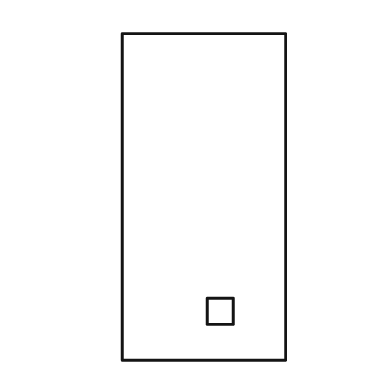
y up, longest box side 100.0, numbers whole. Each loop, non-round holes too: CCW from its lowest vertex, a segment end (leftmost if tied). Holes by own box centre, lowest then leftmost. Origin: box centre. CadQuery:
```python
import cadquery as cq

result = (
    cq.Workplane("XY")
    .moveTo(-25.0, -50.0)
    .lineTo(25.0, -50.0)
    .lineTo(25.0, 50.0)
    .lineTo(-25.0, 50.0)
    .close()
    .moveTo(1.0, -39.0)
    .lineTo(9.0, -39.0)
    .lineTo(9.0, -31.0)
    .lineTo(1.0, -31.0)
    .close()
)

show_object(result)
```